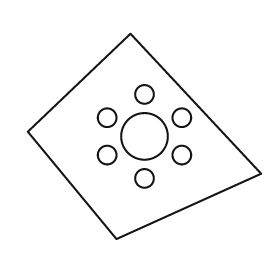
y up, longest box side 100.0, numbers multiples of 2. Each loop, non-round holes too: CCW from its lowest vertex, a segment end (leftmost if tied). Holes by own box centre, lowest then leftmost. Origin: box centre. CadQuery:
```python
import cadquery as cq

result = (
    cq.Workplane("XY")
    .moveTo(-12.0, -44.0)
    .lineTo(50.0, -16.0)
    .lineTo(-6.0, 44.0)
    .lineTo(-50.0, 2.0)
    .close()
    .moveTo(0.0, -18.0)
    .circle(4.0)
    .moveTo(-16.0, -8.0)
    .circle(4.0)
    .moveTo(16.0, -8.0)
    .circle(4.0)
    .moveTo(0.0, 0.0)
    .circle(10.0)
    .moveTo(-16.0, 8.0)
    .circle(4.0)
    .moveTo(16.0, 8.0)
    .circle(4.0)
    .moveTo(0.0, 18.0)
    .circle(4.0)
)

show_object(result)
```